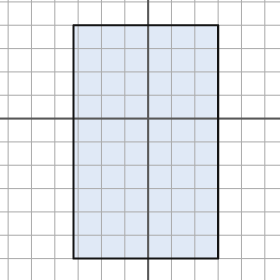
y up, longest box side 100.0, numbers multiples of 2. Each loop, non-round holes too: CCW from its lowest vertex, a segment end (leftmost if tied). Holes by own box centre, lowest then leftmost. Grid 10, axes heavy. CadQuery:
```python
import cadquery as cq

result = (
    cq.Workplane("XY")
    .moveTo(-32.0, -60.0)
    .lineTo(30.0, -60.0)
    .lineTo(30.0, 40.0)
    .lineTo(-32.0, 40.0)
    .close()
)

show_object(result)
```